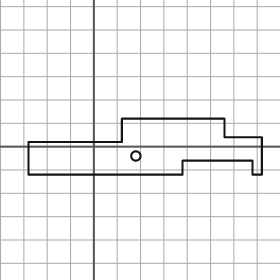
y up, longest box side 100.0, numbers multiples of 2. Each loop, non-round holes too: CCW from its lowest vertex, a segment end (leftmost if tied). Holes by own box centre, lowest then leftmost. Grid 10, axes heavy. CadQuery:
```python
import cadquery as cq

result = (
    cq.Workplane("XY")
    .moveTo(-28.0, -12.0)
    .lineTo(38.0, -12.0)
    .lineTo(38.0, -6.0)
    .lineTo(68.0, -6.0)
    .lineTo(68.0, -12.0)
    .lineTo(72.0, -12.0)
    .lineTo(72.0, 4.0)
    .lineTo(56.0, 4.0)
    .lineTo(56.0, 12.0)
    .lineTo(12.0, 12.0)
    .lineTo(12.0, 2.0)
    .lineTo(-28.0, 2.0)
    .close()
    .moveTo(18.0, -4.0)
    .circle(2.0)
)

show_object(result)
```